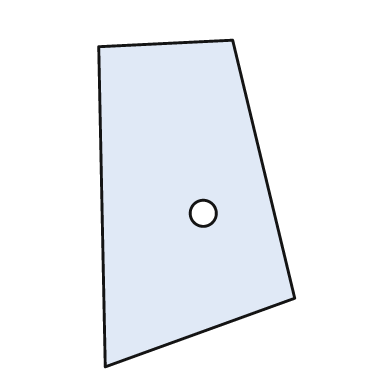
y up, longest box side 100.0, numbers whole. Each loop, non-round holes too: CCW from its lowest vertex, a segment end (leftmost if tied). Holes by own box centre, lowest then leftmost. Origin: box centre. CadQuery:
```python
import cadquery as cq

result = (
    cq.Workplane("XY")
    .moveTo(-28.0, -50.0)
    .lineTo(30.0, -29.0)
    .lineTo(11.0, 50.0)
    .lineTo(-30.0, 48.0)
    .close()
    .moveTo(2.0, -3.0)
    .circle(4.0)
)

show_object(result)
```